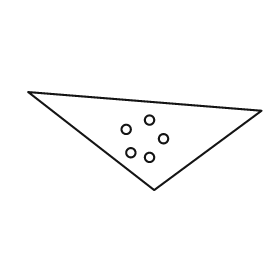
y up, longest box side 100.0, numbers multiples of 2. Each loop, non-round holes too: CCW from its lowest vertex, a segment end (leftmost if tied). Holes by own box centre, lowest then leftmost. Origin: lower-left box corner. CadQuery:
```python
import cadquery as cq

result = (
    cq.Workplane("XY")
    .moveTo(54.0, 0.0)
    .lineTo(100.0, 34.0)
    .lineTo(0.0, 42.0)
    .close()
    .moveTo(52.0, 14.0)
    .circle(2.0)
    .moveTo(44.0, 16.0)
    .circle(2.0)
    .moveTo(58.0, 22.0)
    .circle(2.0)
    .moveTo(42.0, 26.0)
    .circle(2.0)
    .moveTo(52.0, 30.0)
    .circle(2.0)
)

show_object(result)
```